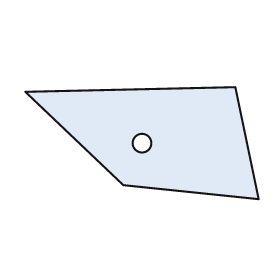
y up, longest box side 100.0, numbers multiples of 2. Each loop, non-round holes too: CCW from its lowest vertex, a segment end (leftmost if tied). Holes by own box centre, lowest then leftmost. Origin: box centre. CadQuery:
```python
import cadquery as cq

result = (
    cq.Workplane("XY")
    .moveTo(50.0, -24.0)
    .lineTo(40.0, 24.0)
    .lineTo(-50.0, 22.0)
    .lineTo(-8.0, -18.0)
    .close()
    .moveTo(0.0, 0.0)
    .circle(4.0)
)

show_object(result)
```